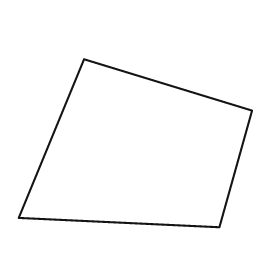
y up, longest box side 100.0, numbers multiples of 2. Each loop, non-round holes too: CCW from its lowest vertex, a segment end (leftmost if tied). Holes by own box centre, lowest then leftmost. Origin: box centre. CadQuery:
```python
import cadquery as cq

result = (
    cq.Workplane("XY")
    .moveTo(36.0, -36.0)
    .lineTo(50.0, 14.0)
    .lineTo(-22.0, 36.0)
    .lineTo(-50.0, -32.0)
    .close()
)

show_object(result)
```